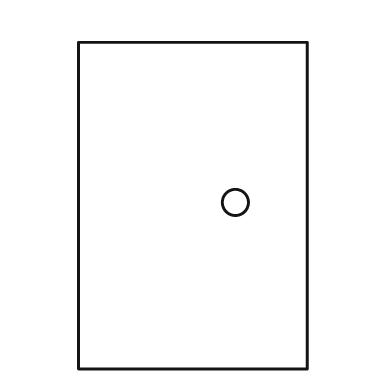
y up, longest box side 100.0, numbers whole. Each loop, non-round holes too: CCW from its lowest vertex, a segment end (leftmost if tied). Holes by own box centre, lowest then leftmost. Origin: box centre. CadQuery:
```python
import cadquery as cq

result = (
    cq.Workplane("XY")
    .moveTo(-35.0, -50.0)
    .lineTo(35.0, -50.0)
    .lineTo(35.0, 50.0)
    .lineTo(-35.0, 50.0)
    .close()
    .moveTo(13.0, 1.0)
    .circle(4.0)
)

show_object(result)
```